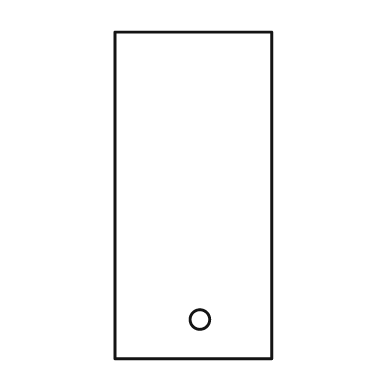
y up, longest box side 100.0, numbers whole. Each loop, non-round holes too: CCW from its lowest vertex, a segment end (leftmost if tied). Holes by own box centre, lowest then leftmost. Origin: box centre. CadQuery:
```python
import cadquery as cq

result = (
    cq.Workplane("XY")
    .moveTo(-24.0, -50.0)
    .lineTo(24.0, -50.0)
    .lineTo(24.0, 50.0)
    .lineTo(-24.0, 50.0)
    .close()
    .moveTo(2.0, -38.0)
    .circle(3.0)
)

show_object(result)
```